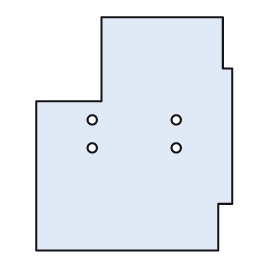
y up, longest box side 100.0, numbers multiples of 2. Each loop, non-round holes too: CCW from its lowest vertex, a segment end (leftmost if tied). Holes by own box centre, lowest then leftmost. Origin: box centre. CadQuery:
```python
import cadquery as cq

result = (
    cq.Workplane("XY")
    .moveTo(-42.0, -50.0)
    .lineTo(36.0, -50.0)
    .lineTo(36.0, -30.0)
    .lineTo(42.0, -30.0)
    .lineTo(42.0, 28.0)
    .lineTo(38.0, 28.0)
    .lineTo(38.0, 50.0)
    .lineTo(-14.0, 50.0)
    .lineTo(-14.0, 14.0)
    .lineTo(-42.0, 14.0)
    .close()
    .moveTo(-18.0, -6.0)
    .circle(2.0)
    .moveTo(18.0, -6.0)
    .circle(2.0)
    .moveTo(-18.0, 6.0)
    .circle(2.0)
    .moveTo(18.0, 6.0)
    .circle(2.0)
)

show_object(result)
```